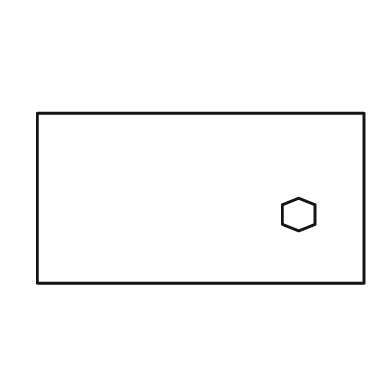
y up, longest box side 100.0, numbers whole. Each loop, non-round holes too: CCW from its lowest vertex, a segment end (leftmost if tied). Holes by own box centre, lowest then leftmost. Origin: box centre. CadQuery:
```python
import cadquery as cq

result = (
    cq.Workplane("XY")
    .moveTo(-50.0, -26.0)
    .lineTo(50.0, -26.0)
    .lineTo(50.0, 26.0)
    .lineTo(-50.0, 26.0)
    .close()
    .moveTo(30.0, -10.0)
    .lineTo(35.0, -8.0)
    .lineTo(35.0, -2.0)
    .lineTo(30.0, 0.0)
    .lineTo(25.0, -2.0)
    .lineTo(25.0, -8.0)
    .close()
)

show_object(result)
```